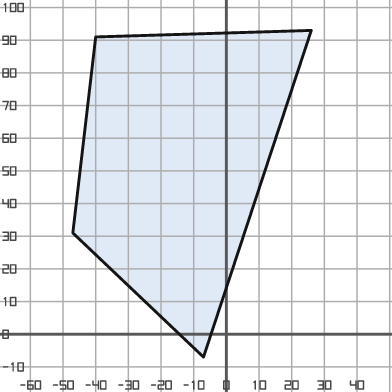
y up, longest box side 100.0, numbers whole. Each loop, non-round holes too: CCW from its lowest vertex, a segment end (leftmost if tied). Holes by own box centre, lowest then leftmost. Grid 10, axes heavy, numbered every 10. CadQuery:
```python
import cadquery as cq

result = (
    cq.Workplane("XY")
    .moveTo(-7.0, -7.0)
    .lineTo(26.0, 93.0)
    .lineTo(-40.0, 91.0)
    .lineTo(-47.0, 31.0)
    .close()
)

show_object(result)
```